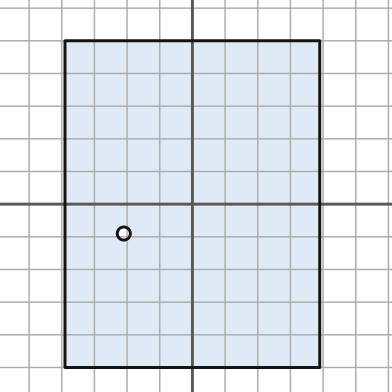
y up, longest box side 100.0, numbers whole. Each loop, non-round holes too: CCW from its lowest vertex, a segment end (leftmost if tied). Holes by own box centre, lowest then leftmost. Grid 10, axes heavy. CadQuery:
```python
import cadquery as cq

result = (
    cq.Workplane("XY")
    .moveTo(-39.0, -50.0)
    .lineTo(39.0, -50.0)
    .lineTo(39.0, 50.0)
    .lineTo(-39.0, 50.0)
    .close()
    .moveTo(-21.0, -9.0)
    .circle(2.0)
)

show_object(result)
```